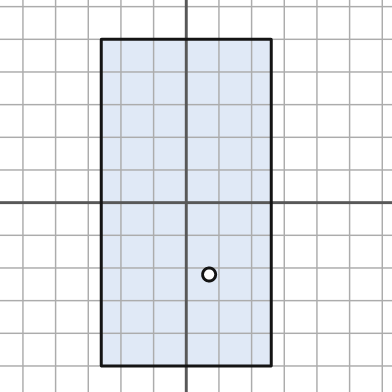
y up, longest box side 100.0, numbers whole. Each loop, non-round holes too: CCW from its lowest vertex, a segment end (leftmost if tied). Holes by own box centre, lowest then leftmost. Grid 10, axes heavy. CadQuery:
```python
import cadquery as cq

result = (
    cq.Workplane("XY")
    .moveTo(-26.0, -50.0)
    .lineTo(26.0, -50.0)
    .lineTo(26.0, 50.0)
    .lineTo(-26.0, 50.0)
    .close()
    .moveTo(7.0, -22.0)
    .circle(2.0)
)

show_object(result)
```